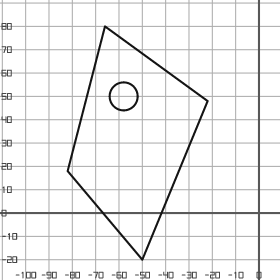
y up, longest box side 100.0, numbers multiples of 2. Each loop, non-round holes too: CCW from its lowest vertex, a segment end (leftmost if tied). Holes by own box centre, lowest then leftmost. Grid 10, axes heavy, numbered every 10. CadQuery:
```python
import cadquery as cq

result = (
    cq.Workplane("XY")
    .moveTo(-50.0, -20.0)
    .lineTo(-22.0, 48.0)
    .lineTo(-66.0, 80.0)
    .lineTo(-82.0, 18.0)
    .close()
    .moveTo(-58.0, 50.0)
    .circle(6.0)
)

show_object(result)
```